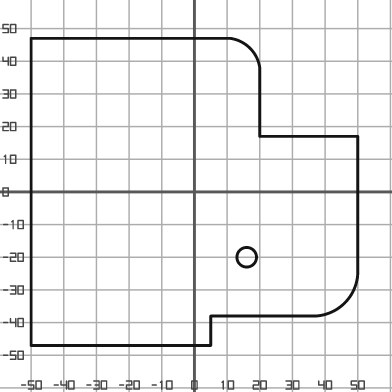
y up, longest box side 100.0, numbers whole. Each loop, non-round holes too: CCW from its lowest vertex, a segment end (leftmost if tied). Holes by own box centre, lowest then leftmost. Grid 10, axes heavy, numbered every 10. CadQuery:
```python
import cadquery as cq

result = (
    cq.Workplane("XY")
    .moveTo(-50.0, -47.0)
    .lineTo(5.0, -47.0)
    .lineTo(5.0, -38.0)
    .lineTo(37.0, -38.0)
    .threePointArc((46.0, -34.0), (50.0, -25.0))
    .lineTo(50.0, 17.0)
    .lineTo(20.0, 17.0)
    .lineTo(20.0, 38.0)
    .threePointArc((17.0, 44.0), (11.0, 47.0))
    .lineTo(-50.0, 47.0)
    .close()
    .moveTo(16.0, -20.0)
    .circle(3.0)
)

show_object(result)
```